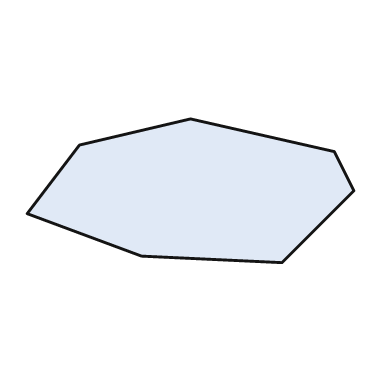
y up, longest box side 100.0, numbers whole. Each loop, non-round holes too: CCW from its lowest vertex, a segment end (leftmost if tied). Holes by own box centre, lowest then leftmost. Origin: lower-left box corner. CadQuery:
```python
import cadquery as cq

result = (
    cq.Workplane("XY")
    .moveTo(78.0, 0.0)
    .lineTo(100.0, 22.0)
    .lineTo(94.0, 34.0)
    .lineTo(50.0, 44.0)
    .lineTo(16.0, 36.0)
    .lineTo(0.0, 15.0)
    .lineTo(35.0, 2.0)
    .close()
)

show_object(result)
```